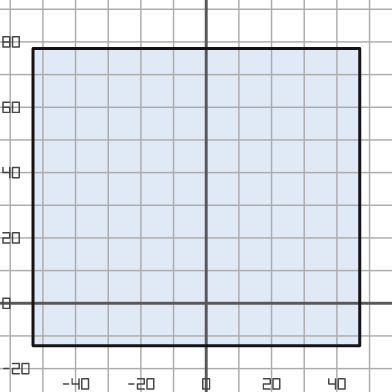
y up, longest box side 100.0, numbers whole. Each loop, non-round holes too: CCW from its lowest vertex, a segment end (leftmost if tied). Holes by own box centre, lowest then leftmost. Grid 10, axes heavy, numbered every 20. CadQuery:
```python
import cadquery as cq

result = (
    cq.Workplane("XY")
    .moveTo(-53.0, -13.0)
    .lineTo(47.0, -13.0)
    .lineTo(47.0, 78.0)
    .lineTo(-53.0, 78.0)
    .close()
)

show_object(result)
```